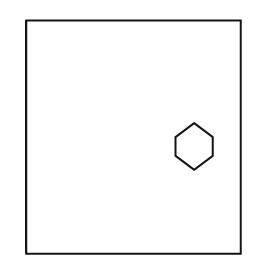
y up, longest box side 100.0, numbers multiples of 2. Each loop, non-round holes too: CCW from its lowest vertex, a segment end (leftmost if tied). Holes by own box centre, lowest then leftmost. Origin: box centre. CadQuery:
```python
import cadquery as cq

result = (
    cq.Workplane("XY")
    .moveTo(-46.0, -50.0)
    .lineTo(46.0, -50.0)
    .lineTo(46.0, 50.0)
    .lineTo(-46.0, 50.0)
    .close()
    .moveTo(26.0, -14.0)
    .lineTo(34.0, -8.0)
    .lineTo(34.0, 0.0)
    .lineTo(26.0, 6.0)
    .lineTo(18.0, 0.0)
    .lineTo(18.0, -8.0)
    .close()
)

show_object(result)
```